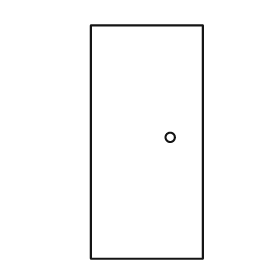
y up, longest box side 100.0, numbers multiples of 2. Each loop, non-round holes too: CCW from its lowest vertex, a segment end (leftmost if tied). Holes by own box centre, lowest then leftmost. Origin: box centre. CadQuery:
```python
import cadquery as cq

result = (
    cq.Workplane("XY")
    .moveTo(-24.0, -50.0)
    .lineTo(24.0, -50.0)
    .lineTo(24.0, 50.0)
    .lineTo(-24.0, 50.0)
    .close()
    .moveTo(10.0, 2.0)
    .circle(2.0)
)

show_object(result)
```